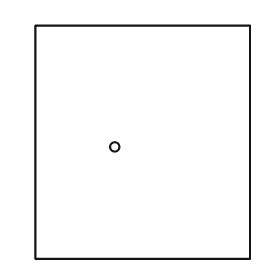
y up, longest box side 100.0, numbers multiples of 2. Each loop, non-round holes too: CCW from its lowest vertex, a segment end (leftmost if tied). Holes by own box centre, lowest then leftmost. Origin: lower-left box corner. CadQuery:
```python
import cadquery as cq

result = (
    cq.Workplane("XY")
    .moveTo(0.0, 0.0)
    .lineTo(92.0, 0.0)
    .lineTo(92.0, 100.0)
    .lineTo(0.0, 100.0)
    .close()
    .moveTo(34.0, 48.0)
    .circle(2.0)
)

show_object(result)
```